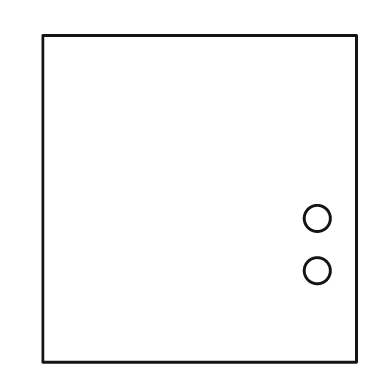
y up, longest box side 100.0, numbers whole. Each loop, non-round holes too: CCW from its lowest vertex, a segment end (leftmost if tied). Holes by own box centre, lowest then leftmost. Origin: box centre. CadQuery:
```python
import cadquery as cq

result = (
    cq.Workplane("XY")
    .moveTo(-48.0, -50.0)
    .lineTo(48.0, -50.0)
    .lineTo(48.0, 50.0)
    .lineTo(-48.0, 50.0)
    .close()
    .moveTo(36.0, -22.0)
    .circle(4.0)
    .moveTo(36.0, -6.0)
    .circle(4.0)
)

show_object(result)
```